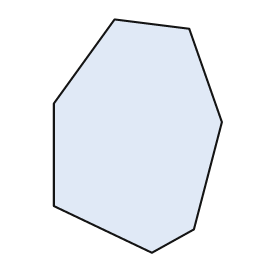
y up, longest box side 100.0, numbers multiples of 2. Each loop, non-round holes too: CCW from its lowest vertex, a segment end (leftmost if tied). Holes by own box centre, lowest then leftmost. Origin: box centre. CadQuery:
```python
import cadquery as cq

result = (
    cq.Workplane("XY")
    .moveTo(6.0, -50.0)
    .lineTo(24.0, -40.0)
    .lineTo(36.0, 6.0)
    .lineTo(22.0, 46.0)
    .lineTo(-10.0, 50.0)
    .lineTo(-36.0, 14.0)
    .lineTo(-36.0, -30.0)
    .close()
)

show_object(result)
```